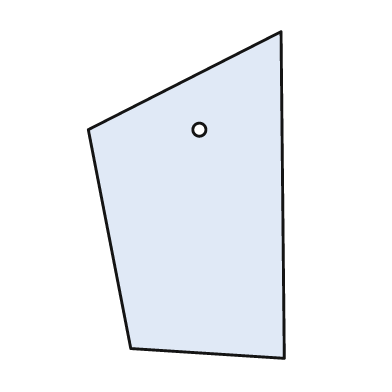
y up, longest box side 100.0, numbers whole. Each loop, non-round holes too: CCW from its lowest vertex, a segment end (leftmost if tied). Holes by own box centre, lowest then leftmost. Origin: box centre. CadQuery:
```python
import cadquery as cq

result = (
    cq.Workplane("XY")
    .moveTo(30.0, -50.0)
    .lineTo(29.0, 50.0)
    .lineTo(-30.0, 20.0)
    .lineTo(-17.0, -47.0)
    .close()
    .moveTo(4.0, 20.0)
    .circle(2.0)
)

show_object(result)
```